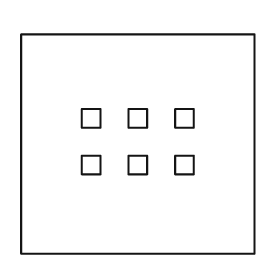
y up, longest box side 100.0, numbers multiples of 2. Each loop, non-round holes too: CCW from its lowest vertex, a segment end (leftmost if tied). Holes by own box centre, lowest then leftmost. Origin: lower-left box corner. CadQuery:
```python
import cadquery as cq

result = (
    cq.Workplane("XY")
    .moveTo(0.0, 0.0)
    .lineTo(100.0, 0.0)
    .lineTo(100.0, 94.0)
    .lineTo(0.0, 94.0)
    .close()
    .moveTo(26.0, 34.0)
    .lineTo(34.0, 34.0)
    .lineTo(34.0, 42.0)
    .lineTo(26.0, 42.0)
    .close()
    .moveTo(46.0, 34.0)
    .lineTo(54.0, 34.0)
    .lineTo(54.0, 42.0)
    .lineTo(46.0, 42.0)
    .close()
    .moveTo(66.0, 34.0)
    .lineTo(74.0, 34.0)
    .lineTo(74.0, 42.0)
    .lineTo(66.0, 42.0)
    .close()
    .moveTo(26.0, 54.0)
    .lineTo(34.0, 54.0)
    .lineTo(34.0, 62.0)
    .lineTo(26.0, 62.0)
    .close()
    .moveTo(46.0, 54.0)
    .lineTo(54.0, 54.0)
    .lineTo(54.0, 62.0)
    .lineTo(46.0, 62.0)
    .close()
    .moveTo(66.0, 54.0)
    .lineTo(74.0, 54.0)
    .lineTo(74.0, 62.0)
    .lineTo(66.0, 62.0)
    .close()
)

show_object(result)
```